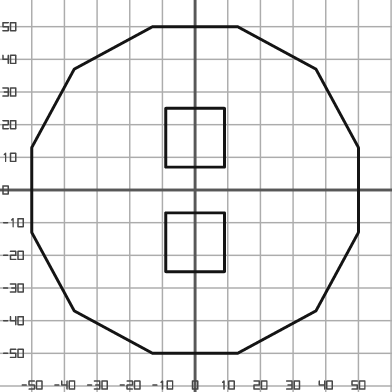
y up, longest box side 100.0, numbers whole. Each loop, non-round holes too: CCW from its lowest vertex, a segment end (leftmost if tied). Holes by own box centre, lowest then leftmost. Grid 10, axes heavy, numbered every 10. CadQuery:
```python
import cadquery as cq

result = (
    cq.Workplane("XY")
    .moveTo(-13.0, -50.0)
    .lineTo(13.0, -50.0)
    .lineTo(37.0, -37.0)
    .lineTo(50.0, -13.0)
    .lineTo(50.0, 13.0)
    .lineTo(37.0, 37.0)
    .lineTo(13.0, 50.0)
    .lineTo(-13.0, 50.0)
    .lineTo(-37.0, 37.0)
    .lineTo(-50.0, 13.0)
    .lineTo(-50.0, -13.0)
    .lineTo(-37.0, -37.0)
    .close()
    .moveTo(-9.0, -25.0)
    .lineTo(9.0, -25.0)
    .lineTo(9.0, -7.0)
    .lineTo(-9.0, -7.0)
    .close()
    .moveTo(-9.0, 7.0)
    .lineTo(9.0, 7.0)
    .lineTo(9.0, 25.0)
    .lineTo(-9.0, 25.0)
    .close()
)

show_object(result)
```